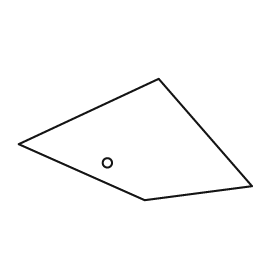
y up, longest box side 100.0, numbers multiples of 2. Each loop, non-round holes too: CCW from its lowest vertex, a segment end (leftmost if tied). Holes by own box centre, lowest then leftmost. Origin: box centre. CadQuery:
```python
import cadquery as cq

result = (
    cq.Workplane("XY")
    .moveTo(4.0, -26.0)
    .lineTo(50.0, -20.0)
    .lineTo(10.0, 26.0)
    .lineTo(-50.0, -2.0)
    .close()
    .moveTo(-12.0, -10.0)
    .circle(2.0)
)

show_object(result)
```